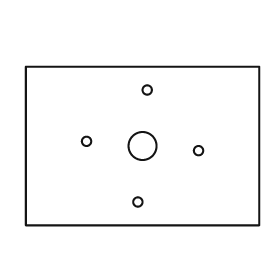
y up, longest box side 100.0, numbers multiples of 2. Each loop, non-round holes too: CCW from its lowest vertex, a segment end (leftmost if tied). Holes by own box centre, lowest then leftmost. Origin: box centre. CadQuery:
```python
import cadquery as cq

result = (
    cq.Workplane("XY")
    .moveTo(-50.0, -34.0)
    .lineTo(50.0, -34.0)
    .lineTo(50.0, 34.0)
    .lineTo(-50.0, 34.0)
    .close()
    .moveTo(-2.0, -24.0)
    .circle(2.0)
    .moveTo(24.0, -2.0)
    .circle(2.0)
    .moveTo(0.0, 0.0)
    .circle(6.0)
    .moveTo(-24.0, 2.0)
    .circle(2.0)
    .moveTo(2.0, 24.0)
    .circle(2.0)
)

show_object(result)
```